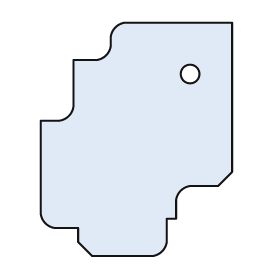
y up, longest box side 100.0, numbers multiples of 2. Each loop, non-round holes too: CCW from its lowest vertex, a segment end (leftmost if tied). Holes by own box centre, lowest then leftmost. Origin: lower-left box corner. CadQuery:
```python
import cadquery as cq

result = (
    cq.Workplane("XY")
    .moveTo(22.0, 0.0)
    .lineTo(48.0, 0.0)
    .threePointArc((52.0, 2.0), (54.0, 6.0))
    .lineTo(54.0, 16.0)
    .lineTo(58.0, 16.0)
    .lineTo(58.0, 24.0)
    .threePointArc((60.0, 28.0), (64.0, 30.0))
    .lineTo(76.0, 30.0)
    .lineTo(82.0, 36.0)
    .lineTo(82.0, 100.0)
    .lineTo(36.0, 100.0)
    .threePointArc((32.0, 98.0), (30.0, 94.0))
    .lineTo(30.0, 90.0)
    .threePointArc((28.0, 86.0), (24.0, 84.0))
    .lineTo(14.0, 84.0)
    .lineTo(14.0, 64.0)
    .threePointArc((12.0, 60.0), (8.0, 58.0))
    .lineTo(0.0, 58.0)
    .lineTo(0.0, 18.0)
    .threePointArc((2.0, 14.0), (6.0, 12.0))
    .lineTo(16.0, 12.0)
    .lineTo(16.0, 6.0)
    .close()
    .moveTo(64.0, 78.0)
    .circle(4.0)
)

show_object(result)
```